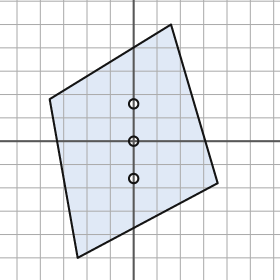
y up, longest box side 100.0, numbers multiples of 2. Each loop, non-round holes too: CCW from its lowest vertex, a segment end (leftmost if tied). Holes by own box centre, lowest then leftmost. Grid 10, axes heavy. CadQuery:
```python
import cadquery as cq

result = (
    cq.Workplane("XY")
    .moveTo(-24.0, -50.0)
    .lineTo(36.0, -18.0)
    .lineTo(16.0, 50.0)
    .lineTo(-36.0, 18.0)
    .close()
    .moveTo(0.0, -16.0)
    .circle(2.0)
    .moveTo(0.0, 0.0)
    .circle(2.0)
    .moveTo(0.0, 16.0)
    .circle(2.0)
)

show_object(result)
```